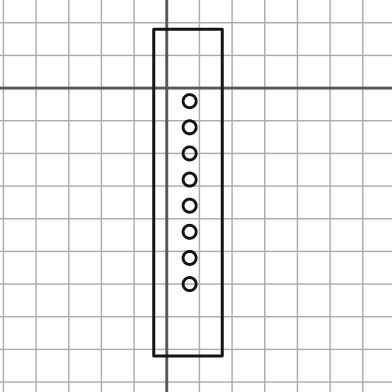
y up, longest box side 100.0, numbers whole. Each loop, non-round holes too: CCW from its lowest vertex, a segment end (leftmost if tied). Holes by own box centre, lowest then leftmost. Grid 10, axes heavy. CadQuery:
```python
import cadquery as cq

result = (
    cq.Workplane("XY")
    .moveTo(-4.0, -82.0)
    .lineTo(17.0, -82.0)
    .lineTo(17.0, 18.0)
    .lineTo(-4.0, 18.0)
    .close()
    .moveTo(7.0, -60.0)
    .circle(2.0)
    .moveTo(7.0, -52.0)
    .circle(2.0)
    .moveTo(7.0, -44.0)
    .circle(2.0)
    .moveTo(7.0, -36.0)
    .circle(2.0)
    .moveTo(7.0, -28.0)
    .circle(2.0)
    .moveTo(7.0, -20.0)
    .circle(2.0)
    .moveTo(7.0, -12.0)
    .circle(2.0)
    .moveTo(7.0, -4.0)
    .circle(2.0)
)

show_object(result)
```